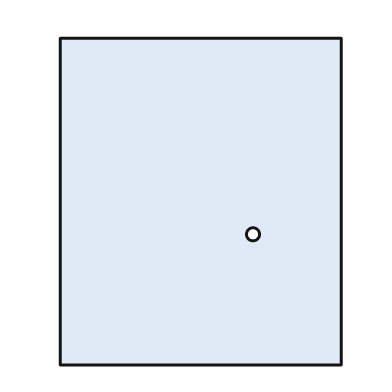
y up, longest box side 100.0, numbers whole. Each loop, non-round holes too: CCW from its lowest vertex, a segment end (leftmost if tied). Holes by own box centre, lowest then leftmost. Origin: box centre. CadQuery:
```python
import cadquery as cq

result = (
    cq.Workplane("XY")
    .moveTo(-43.0, -50.0)
    .lineTo(43.0, -50.0)
    .lineTo(43.0, 50.0)
    .lineTo(-43.0, 50.0)
    .close()
    .moveTo(16.0, -10.0)
    .circle(2.0)
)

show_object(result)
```